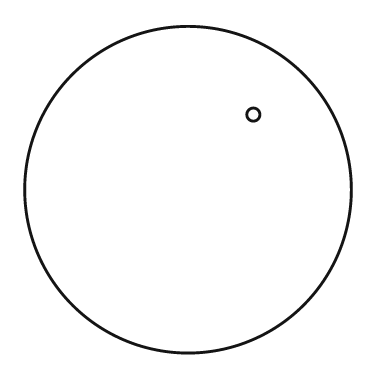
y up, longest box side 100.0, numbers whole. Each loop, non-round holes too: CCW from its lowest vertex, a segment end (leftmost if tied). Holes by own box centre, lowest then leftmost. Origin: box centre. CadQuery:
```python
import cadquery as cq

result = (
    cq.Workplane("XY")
    .moveTo(0.0, 0.0)
    .circle(50.0)
    .moveTo(20.0, 23.0)
    .circle(2.0)
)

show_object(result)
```